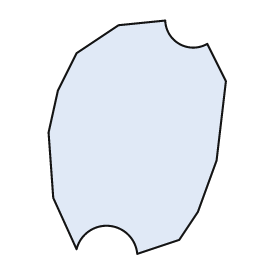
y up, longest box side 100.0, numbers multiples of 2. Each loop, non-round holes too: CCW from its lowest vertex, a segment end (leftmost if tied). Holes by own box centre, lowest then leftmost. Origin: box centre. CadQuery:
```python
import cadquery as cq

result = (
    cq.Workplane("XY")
    .moveTo(0.0, -50.0)
    .lineTo(18.0, -44.0)
    .lineTo(26.0, -32.0)
    .lineTo(34.0, -10.0)
    .lineTo(38.0, 24.0)
    .lineTo(30.0, 40.0)
    .threePointArc((18.0, 40.0), (12.0, 50.0))
    .lineTo(-8.0, 48.0)
    .lineTo(-26.0, 36.0)
    .lineTo(-34.0, 20.0)
    .lineTo(-38.0, 2.0)
    .lineTo(-36.0, -26.0)
    .lineTo(-26.0, -48.0)
    .threePointArc((-12.0, -38.0), (0.0, -50.0))
    .close()
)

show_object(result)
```